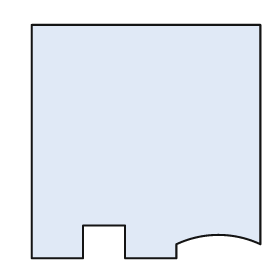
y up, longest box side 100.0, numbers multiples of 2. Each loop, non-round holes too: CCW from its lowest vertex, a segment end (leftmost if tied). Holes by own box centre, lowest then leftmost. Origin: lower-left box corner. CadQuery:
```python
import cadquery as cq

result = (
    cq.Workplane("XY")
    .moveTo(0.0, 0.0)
    .lineTo(22.0, 0.0)
    .lineTo(22.0, 14.0)
    .lineTo(40.0, 14.0)
    .lineTo(40.0, 0.0)
    .lineTo(62.0, 0.0)
    .lineTo(62.0, 6.0)
    .threePointArc((80.0, 10.0), (98.0, 6.0))
    .lineTo(98.0, 100.0)
    .lineTo(0.0, 100.0)
    .close()
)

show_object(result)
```